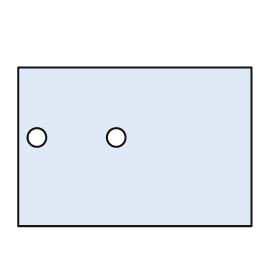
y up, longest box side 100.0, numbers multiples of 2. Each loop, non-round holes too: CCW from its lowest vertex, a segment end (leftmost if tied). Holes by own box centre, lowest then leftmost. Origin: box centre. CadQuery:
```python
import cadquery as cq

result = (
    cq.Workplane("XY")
    .moveTo(-50.0, -34.0)
    .lineTo(50.0, -34.0)
    .lineTo(50.0, 34.0)
    .lineTo(-50.0, 34.0)
    .close()
    .moveTo(-42.0, 4.0)
    .circle(4.0)
    .moveTo(-8.0, 4.0)
    .circle(4.0)
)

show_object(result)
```